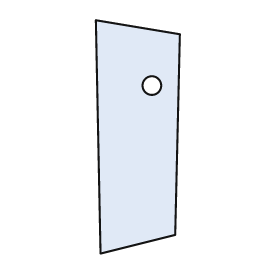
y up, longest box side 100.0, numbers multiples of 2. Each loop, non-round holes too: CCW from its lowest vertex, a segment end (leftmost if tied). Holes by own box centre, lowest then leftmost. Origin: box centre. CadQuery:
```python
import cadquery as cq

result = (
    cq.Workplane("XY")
    .moveTo(-16.0, -50.0)
    .lineTo(16.0, -42.0)
    .lineTo(18.0, 44.0)
    .lineTo(-18.0, 50.0)
    .close()
    .moveTo(6.0, 22.0)
    .circle(4.0)
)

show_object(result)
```